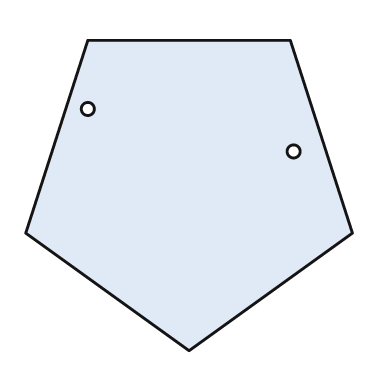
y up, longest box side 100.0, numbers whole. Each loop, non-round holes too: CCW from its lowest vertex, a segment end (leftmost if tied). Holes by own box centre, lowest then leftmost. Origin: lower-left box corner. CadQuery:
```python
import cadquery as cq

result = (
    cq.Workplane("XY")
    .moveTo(50.0, 0.0)
    .lineTo(100.0, 36.0)
    .lineTo(81.0, 95.0)
    .lineTo(19.0, 95.0)
    .lineTo(0.0, 36.0)
    .close()
    .moveTo(82.0, 61.0)
    .circle(2.0)
    .moveTo(19.0, 74.0)
    .circle(2.0)
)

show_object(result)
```